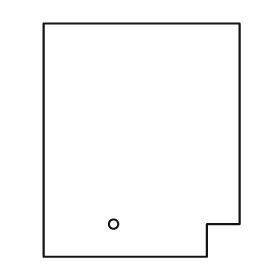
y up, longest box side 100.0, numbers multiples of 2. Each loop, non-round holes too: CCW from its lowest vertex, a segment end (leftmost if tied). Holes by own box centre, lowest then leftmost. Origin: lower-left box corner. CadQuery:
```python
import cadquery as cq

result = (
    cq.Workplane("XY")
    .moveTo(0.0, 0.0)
    .lineTo(70.0, 0.0)
    .lineTo(70.0, 14.0)
    .lineTo(84.0, 14.0)
    .lineTo(84.0, 100.0)
    .lineTo(0.0, 100.0)
    .close()
    .moveTo(30.0, 14.0)
    .circle(2.0)
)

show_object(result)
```